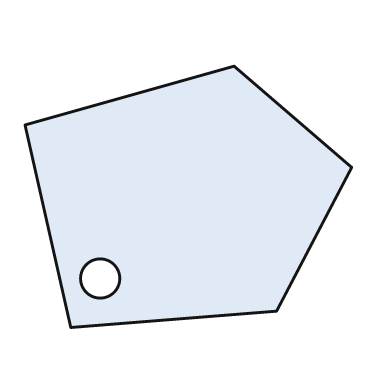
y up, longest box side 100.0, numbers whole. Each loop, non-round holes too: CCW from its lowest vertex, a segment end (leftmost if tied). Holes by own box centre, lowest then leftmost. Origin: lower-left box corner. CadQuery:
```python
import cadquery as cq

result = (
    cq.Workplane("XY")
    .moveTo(14.0, 0.0)
    .lineTo(77.0, 5.0)
    .lineTo(100.0, 49.0)
    .lineTo(64.0, 80.0)
    .lineTo(0.0, 62.0)
    .close()
    .moveTo(23.0, 15.0)
    .circle(6.0)
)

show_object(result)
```